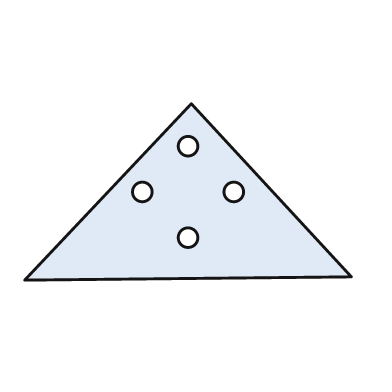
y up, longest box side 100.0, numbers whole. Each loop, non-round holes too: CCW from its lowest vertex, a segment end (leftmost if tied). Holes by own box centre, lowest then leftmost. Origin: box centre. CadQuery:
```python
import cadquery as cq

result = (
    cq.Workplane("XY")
    .moveTo(-50.0, -27.0)
    .lineTo(50.0, -26.0)
    .lineTo(1.0, 27.0)
    .close()
    .moveTo(0.0, -14.0)
    .circle(3.0)
    .moveTo(-14.0, 0.0)
    .circle(3.0)
    .moveTo(14.0, 0.0)
    .circle(3.0)
    .moveTo(0.0, 14.0)
    .circle(3.0)
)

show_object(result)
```